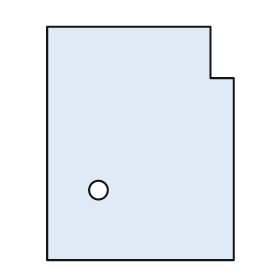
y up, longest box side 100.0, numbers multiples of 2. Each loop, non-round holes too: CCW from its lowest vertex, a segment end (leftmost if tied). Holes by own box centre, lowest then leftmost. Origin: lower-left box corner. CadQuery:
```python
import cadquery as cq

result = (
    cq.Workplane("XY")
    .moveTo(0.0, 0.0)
    .lineTo(80.0, 0.0)
    .lineTo(80.0, 78.0)
    .lineTo(70.0, 78.0)
    .lineTo(70.0, 100.0)
    .lineTo(0.0, 100.0)
    .close()
    .moveTo(22.0, 30.0)
    .circle(4.0)
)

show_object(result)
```